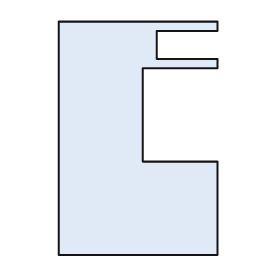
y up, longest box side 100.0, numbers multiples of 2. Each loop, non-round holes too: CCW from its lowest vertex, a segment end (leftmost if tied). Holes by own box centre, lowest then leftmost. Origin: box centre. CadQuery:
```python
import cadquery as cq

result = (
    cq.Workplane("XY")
    .moveTo(-34.0, -50.0)
    .lineTo(34.0, -50.0)
    .lineTo(34.0, -10.0)
    .lineTo(2.0, -10.0)
    .lineTo(2.0, 30.0)
    .lineTo(34.0, 30.0)
    .lineTo(34.0, 34.0)
    .lineTo(8.0, 34.0)
    .lineTo(8.0, 46.0)
    .lineTo(34.0, 46.0)
    .lineTo(34.0, 50.0)
    .lineTo(-34.0, 50.0)
    .close()
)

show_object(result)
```